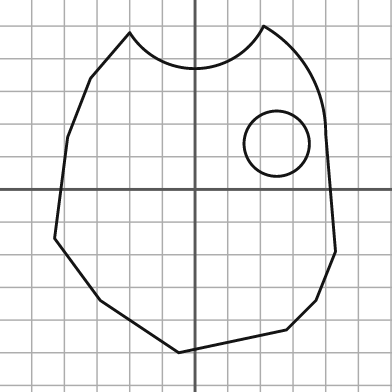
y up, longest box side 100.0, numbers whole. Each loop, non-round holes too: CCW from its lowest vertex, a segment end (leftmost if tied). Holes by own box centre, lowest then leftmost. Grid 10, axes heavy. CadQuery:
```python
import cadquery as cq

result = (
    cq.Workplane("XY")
    .moveTo(-5.0, -50.0)
    .lineTo(28.0, -43.0)
    .lineTo(37.0, -34.0)
    .lineTo(43.0, -19.0)
    .lineTo(40.0, 17.0)
    .threePointArc((35.0, 36.0), (21.0, 50.0))
    .threePointArc((1.0, 37.0), (-20.0, 48.0))
    .lineTo(-32.0, 34.0)
    .lineTo(-39.0, 16.0)
    .lineTo(-43.0, -15.0)
    .lineTo(-29.0, -34.0)
    .close()
    .moveTo(25.0, 14.0)
    .circle(10.0)
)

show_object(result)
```